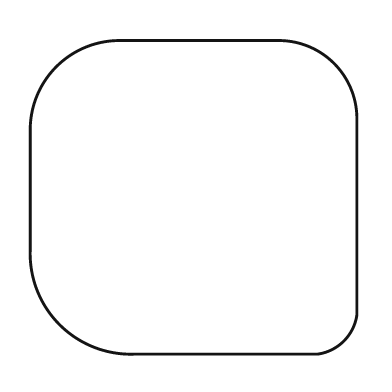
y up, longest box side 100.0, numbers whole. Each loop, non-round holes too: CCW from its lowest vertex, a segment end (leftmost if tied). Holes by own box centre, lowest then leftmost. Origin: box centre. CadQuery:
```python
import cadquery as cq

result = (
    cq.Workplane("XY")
    .moveTo(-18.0, -48.0)
    .lineTo(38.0, -48.0)
    .threePointArc((46.0, -44.0), (50.0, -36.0))
    .lineTo(50.0, 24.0)
    .threePointArc((43.0, 41.0), (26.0, 48.0))
    .lineTo(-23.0, 48.0)
    .threePointArc((-42.0, 40.0), (-50.0, 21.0))
    .lineTo(-50.0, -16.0)
    .threePointArc((-41.0, -39.0), (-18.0, -48.0))
    .close()
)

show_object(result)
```